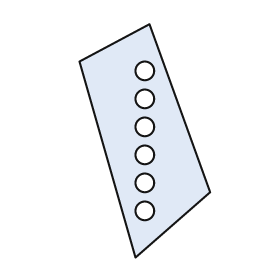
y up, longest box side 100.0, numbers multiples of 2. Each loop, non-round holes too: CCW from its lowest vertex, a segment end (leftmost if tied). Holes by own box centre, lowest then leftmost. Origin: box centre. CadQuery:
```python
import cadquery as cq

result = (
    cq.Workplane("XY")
    .moveTo(-4.0, -50.0)
    .lineTo(28.0, -22.0)
    .lineTo(2.0, 50.0)
    .lineTo(-28.0, 34.0)
    .close()
    .moveTo(0.0, -30.0)
    .circle(4.0)
    .moveTo(0.0, -18.0)
    .circle(4.0)
    .moveTo(0.0, -6.0)
    .circle(4.0)
    .moveTo(0.0, 6.0)
    .circle(4.0)
    .moveTo(0.0, 18.0)
    .circle(4.0)
    .moveTo(0.0, 30.0)
    .circle(4.0)
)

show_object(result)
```